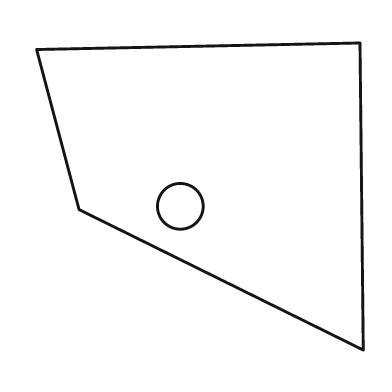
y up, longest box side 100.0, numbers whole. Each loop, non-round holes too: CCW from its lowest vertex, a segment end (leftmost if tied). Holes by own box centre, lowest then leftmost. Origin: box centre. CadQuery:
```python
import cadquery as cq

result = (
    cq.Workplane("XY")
    .moveTo(50.0, -47.0)
    .lineTo(49.0, 47.0)
    .lineTo(-50.0, 45.0)
    .lineTo(-37.0, -4.0)
    .close()
    .moveTo(-6.0, -3.0)
    .circle(7.0)
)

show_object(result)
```